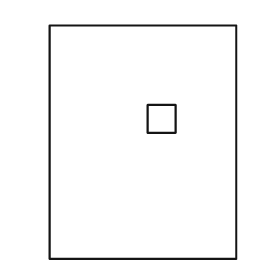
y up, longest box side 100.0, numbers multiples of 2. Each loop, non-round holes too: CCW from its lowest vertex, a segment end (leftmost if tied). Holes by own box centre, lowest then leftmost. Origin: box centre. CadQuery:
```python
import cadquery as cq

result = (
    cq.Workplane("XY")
    .moveTo(-40.0, -50.0)
    .lineTo(40.0, -50.0)
    .lineTo(40.0, 50.0)
    .lineTo(-40.0, 50.0)
    .close()
    .moveTo(2.0, 4.0)
    .lineTo(14.0, 4.0)
    .lineTo(14.0, 16.0)
    .lineTo(2.0, 16.0)
    .close()
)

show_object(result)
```